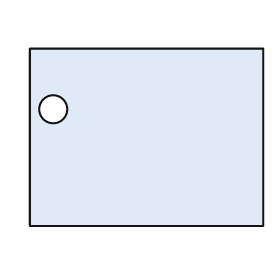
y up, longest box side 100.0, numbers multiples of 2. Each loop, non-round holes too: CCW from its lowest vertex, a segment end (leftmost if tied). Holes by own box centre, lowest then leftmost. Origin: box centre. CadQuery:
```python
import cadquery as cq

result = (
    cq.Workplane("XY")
    .moveTo(-50.0, -38.0)
    .lineTo(50.0, -38.0)
    .lineTo(50.0, 38.0)
    .lineTo(-50.0, 38.0)
    .close()
    .moveTo(-40.0, 12.0)
    .circle(6.0)
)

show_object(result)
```